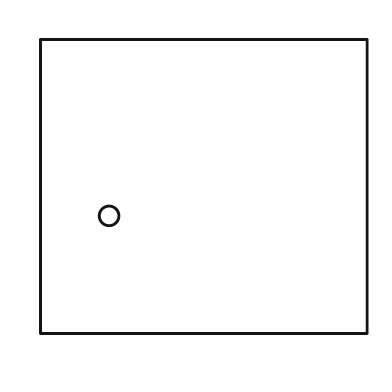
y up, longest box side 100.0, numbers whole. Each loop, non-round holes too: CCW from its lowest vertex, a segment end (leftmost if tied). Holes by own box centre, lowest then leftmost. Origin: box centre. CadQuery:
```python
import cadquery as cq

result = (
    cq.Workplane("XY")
    .moveTo(-50.0, -45.0)
    .lineTo(50.0, -45.0)
    .lineTo(50.0, 45.0)
    .lineTo(-50.0, 45.0)
    .close()
    .moveTo(-29.0, -9.0)
    .circle(3.0)
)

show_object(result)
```